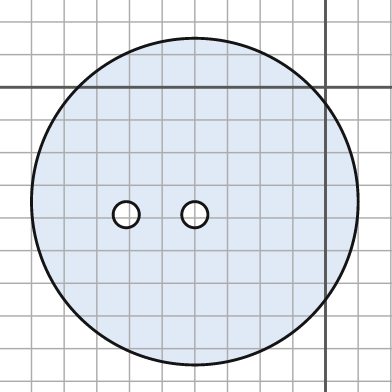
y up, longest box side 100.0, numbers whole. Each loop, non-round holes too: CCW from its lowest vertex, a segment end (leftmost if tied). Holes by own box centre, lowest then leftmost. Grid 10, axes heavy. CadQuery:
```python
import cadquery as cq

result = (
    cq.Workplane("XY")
    .moveTo(-40.0, -35.0)
    .circle(50.0)
    .moveTo(-61.0, -39.0)
    .circle(4.0)
    .moveTo(-40.0, -39.0)
    .circle(4.0)
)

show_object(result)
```